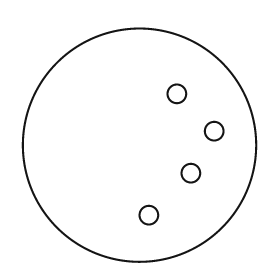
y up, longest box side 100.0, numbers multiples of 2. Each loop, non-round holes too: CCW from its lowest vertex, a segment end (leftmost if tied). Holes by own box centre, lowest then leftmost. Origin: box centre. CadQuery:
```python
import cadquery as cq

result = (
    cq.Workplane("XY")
    .moveTo(0.0, 0.0)
    .circle(50.0)
    .moveTo(4.0, -30.0)
    .circle(4.0)
    .moveTo(22.0, -12.0)
    .circle(4.0)
    .moveTo(32.0, 6.0)
    .circle(4.0)
    .moveTo(16.0, 22.0)
    .circle(4.0)
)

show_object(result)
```